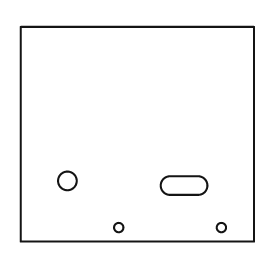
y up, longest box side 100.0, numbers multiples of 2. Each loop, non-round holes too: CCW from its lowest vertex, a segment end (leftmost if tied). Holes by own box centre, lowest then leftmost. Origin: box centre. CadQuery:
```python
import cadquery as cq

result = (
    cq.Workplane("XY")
    .moveTo(-50.0, -46.0)
    .lineTo(50.0, -46.0)
    .lineTo(50.0, 46.0)
    .lineTo(-50.0, 46.0)
    .close()
    .moveTo(-8.0, -40.0)
    .circle(2.0)
    .moveTo(36.0, -40.0)
    .circle(2.0)
    .moveTo(14.0, -26.0)
    .lineTo(26.0, -26.0)
    .threePointArc((30.0, -22.0), (26.0, -18.0))
    .lineTo(14.0, -18.0)
    .threePointArc((10.0, -22.0), (14.0, -26.0))
    .close()
    .moveTo(-30.0, -20.0)
    .circle(4.0)
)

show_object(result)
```